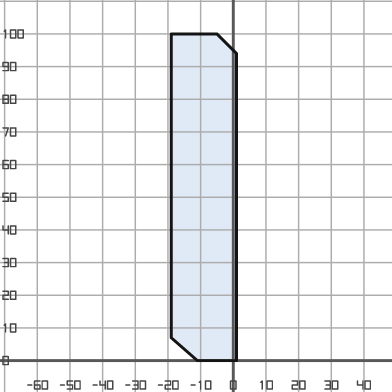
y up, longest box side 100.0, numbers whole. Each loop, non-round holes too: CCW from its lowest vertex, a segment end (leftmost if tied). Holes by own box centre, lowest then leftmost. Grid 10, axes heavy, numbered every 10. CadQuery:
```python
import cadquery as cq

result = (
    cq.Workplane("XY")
    .moveTo(-11.0, 0.0)
    .lineTo(1.0, 0.0)
    .lineTo(1.0, 94.0)
    .lineTo(-5.0, 100.0)
    .lineTo(-19.0, 100.0)
    .lineTo(-19.0, 7.0)
    .close()
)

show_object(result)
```